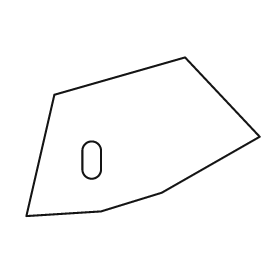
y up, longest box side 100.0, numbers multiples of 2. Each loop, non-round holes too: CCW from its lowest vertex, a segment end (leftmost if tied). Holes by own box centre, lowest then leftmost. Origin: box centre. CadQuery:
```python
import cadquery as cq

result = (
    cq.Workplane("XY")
    .moveTo(-50.0, -34.0)
    .lineTo(-18.0, -32.0)
    .lineTo(8.0, -24.0)
    .lineTo(50.0, 0.0)
    .lineTo(18.0, 34.0)
    .lineTo(-38.0, 18.0)
    .close()
    .moveTo(-26.0, -14.0)
    .threePointArc((-22.0, -18.0), (-18.0, -14.0))
    .lineTo(-18.0, -6.0)
    .threePointArc((-22.0, -2.0), (-26.0, -6.0))
    .close()
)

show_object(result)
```